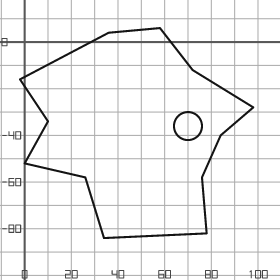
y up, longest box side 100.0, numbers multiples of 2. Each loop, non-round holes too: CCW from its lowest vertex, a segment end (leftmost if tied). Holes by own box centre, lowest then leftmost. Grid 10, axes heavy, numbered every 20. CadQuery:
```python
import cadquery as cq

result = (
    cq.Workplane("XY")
    .moveTo(34.0, -84.0)
    .lineTo(78.0, -82.0)
    .lineTo(76.0, -58.0)
    .lineTo(84.0, -40.0)
    .lineTo(98.0, -28.0)
    .lineTo(72.0, -12.0)
    .lineTo(58.0, 6.0)
    .lineTo(36.0, 4.0)
    .lineTo(-2.0, -16.0)
    .lineTo(10.0, -34.0)
    .lineTo(0.0, -52.0)
    .lineTo(26.0, -58.0)
    .close()
    .moveTo(70.0, -36.0)
    .circle(6.0)
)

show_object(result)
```